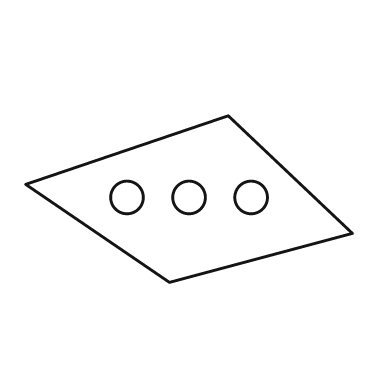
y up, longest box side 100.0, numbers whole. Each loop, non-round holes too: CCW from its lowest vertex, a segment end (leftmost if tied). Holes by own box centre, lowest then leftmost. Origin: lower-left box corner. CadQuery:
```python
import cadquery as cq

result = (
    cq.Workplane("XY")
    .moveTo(44.0, 0.0)
    .lineTo(100.0, 15.0)
    .lineTo(62.0, 51.0)
    .lineTo(0.0, 30.0)
    .close()
    .moveTo(31.0, 26.0)
    .circle(5.0)
    .moveTo(50.0, 26.0)
    .circle(5.0)
    .moveTo(69.0, 26.0)
    .circle(5.0)
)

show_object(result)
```